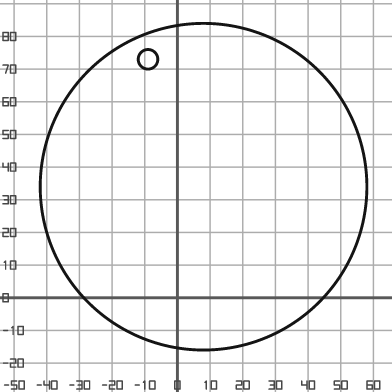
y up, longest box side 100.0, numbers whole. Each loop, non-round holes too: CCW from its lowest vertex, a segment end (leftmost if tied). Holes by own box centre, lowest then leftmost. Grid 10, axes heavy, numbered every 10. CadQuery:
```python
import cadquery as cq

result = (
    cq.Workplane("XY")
    .moveTo(8.0, 34.0)
    .circle(50.0)
    .moveTo(-9.0, 73.0)
    .circle(3.0)
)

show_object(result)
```